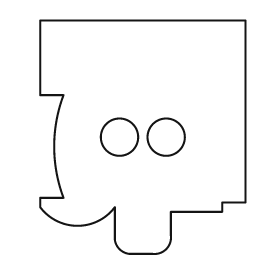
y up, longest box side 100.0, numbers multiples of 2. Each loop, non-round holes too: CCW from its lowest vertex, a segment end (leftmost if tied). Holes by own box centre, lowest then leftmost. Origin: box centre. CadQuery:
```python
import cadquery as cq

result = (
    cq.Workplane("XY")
    .moveTo(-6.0, -50.0)
    .lineTo(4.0, -50.0)
    .threePointArc((10.0, -48.0), (12.0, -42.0))
    .lineTo(12.0, -32.0)
    .lineTo(34.0, -32.0)
    .lineTo(34.0, -28.0)
    .lineTo(44.0, -28.0)
    .lineTo(44.0, 50.0)
    .lineTo(-44.0, 50.0)
    .lineTo(-44.0, 18.0)
    .lineTo(-34.0, 18.0)
    .threePointArc((-38.0, -4.0), (-34.0, -26.0))
    .lineTo(-44.0, -26.0)
    .lineTo(-44.0, -30.0)
    .threePointArc((-28.0, -38.0), (-12.0, -30.0))
    .lineTo(-12.0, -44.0)
    .threePointArc((-10.0, -48.0), (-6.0, -50.0))
    .close()
    .moveTo(-10.0, 0.0)
    .circle(8.0)
    .moveTo(10.0, 0.0)
    .circle(8.0)
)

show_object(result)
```